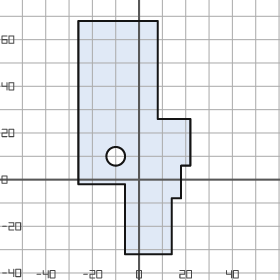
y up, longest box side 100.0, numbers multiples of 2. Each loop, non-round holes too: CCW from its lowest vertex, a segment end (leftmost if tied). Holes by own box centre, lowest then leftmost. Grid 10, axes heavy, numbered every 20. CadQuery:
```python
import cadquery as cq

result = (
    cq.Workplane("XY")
    .moveTo(-6.0, -32.0)
    .lineTo(14.0, -32.0)
    .lineTo(14.0, -8.0)
    .lineTo(18.0, -8.0)
    .lineTo(18.0, 6.0)
    .lineTo(22.0, 6.0)
    .lineTo(22.0, 26.0)
    .lineTo(8.0, 26.0)
    .lineTo(8.0, 68.0)
    .lineTo(-26.0, 68.0)
    .lineTo(-26.0, -2.0)
    .lineTo(-6.0, -2.0)
    .close()
    .moveTo(-10.0, 10.0)
    .circle(4.0)
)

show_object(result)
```